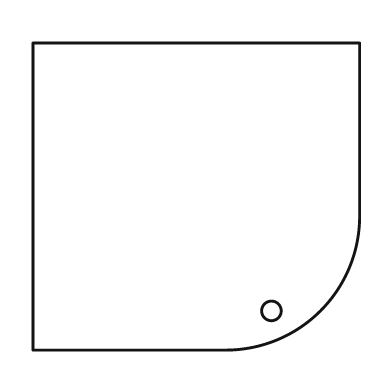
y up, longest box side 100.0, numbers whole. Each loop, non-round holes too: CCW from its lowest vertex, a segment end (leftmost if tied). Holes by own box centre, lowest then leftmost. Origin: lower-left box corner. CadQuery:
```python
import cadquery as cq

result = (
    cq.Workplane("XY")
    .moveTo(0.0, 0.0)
    .lineTo(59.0, 0.0)
    .threePointArc((88.0, 12.0), (100.0, 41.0))
    .lineTo(100.0, 94.0)
    .lineTo(0.0, 94.0)
    .close()
    .moveTo(73.0, 12.0)
    .circle(3.0)
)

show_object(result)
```